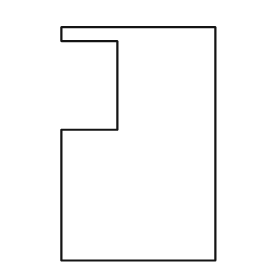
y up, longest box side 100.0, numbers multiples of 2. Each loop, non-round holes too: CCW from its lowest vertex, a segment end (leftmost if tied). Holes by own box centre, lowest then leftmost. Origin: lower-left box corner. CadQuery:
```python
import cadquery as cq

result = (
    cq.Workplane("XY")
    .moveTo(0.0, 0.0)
    .lineTo(66.0, 0.0)
    .lineTo(66.0, 100.0)
    .lineTo(0.0, 100.0)
    .lineTo(0.0, 94.0)
    .lineTo(24.0, 94.0)
    .lineTo(24.0, 56.0)
    .lineTo(0.0, 56.0)
    .close()
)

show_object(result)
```